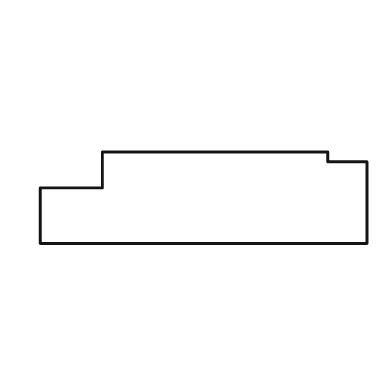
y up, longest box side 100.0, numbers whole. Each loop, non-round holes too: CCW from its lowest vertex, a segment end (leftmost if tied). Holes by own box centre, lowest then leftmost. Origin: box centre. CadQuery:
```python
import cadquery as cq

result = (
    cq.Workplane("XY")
    .moveTo(-50.0, -14.0)
    .lineTo(50.0, -14.0)
    .lineTo(50.0, 11.0)
    .lineTo(38.0, 11.0)
    .lineTo(38.0, 14.0)
    .lineTo(-31.0, 14.0)
    .lineTo(-31.0, 3.0)
    .lineTo(-50.0, 3.0)
    .close()
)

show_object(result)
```